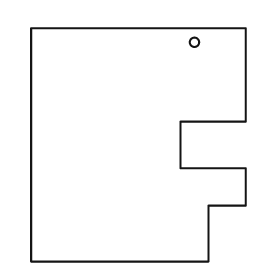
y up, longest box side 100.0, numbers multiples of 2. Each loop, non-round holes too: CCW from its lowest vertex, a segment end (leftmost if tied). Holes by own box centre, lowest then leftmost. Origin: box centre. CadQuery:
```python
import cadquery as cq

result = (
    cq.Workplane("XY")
    .moveTo(-46.0, -50.0)
    .lineTo(30.0, -50.0)
    .lineTo(30.0, -26.0)
    .lineTo(46.0, -26.0)
    .lineTo(46.0, -10.0)
    .lineTo(18.0, -10.0)
    .lineTo(18.0, 10.0)
    .lineTo(46.0, 10.0)
    .lineTo(46.0, 50.0)
    .lineTo(-46.0, 50.0)
    .close()
    .moveTo(24.0, 44.0)
    .circle(2.0)
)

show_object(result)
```